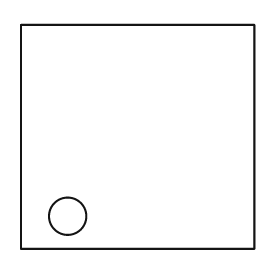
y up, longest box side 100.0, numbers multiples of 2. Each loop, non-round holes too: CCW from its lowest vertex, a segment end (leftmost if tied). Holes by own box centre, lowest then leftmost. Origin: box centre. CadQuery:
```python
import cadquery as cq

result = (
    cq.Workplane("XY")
    .moveTo(-50.0, -48.0)
    .lineTo(50.0, -48.0)
    .lineTo(50.0, 48.0)
    .lineTo(-50.0, 48.0)
    .close()
    .moveTo(-30.0, -34.0)
    .circle(8.0)
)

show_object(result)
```